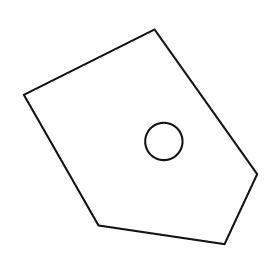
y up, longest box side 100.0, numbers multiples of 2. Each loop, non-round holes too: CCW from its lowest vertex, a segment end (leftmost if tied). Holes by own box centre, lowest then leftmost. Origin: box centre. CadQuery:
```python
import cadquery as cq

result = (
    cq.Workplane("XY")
    .moveTo(36.0, -46.0)
    .lineTo(50.0, -16.0)
    .lineTo(6.0, 46.0)
    .lineTo(-50.0, 18.0)
    .lineTo(-18.0, -38.0)
    .close()
    .moveTo(10.0, -2.0)
    .circle(8.0)
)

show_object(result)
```